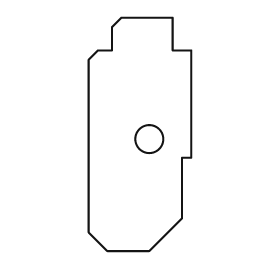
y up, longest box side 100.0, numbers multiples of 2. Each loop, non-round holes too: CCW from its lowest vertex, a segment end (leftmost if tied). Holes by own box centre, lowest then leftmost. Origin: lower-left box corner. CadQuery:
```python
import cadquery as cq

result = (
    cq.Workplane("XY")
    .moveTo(8.0, 0.0)
    .lineTo(26.0, 0.0)
    .lineTo(40.0, 14.0)
    .lineTo(40.0, 40.0)
    .lineTo(44.0, 40.0)
    .lineTo(44.0, 86.0)
    .lineTo(36.0, 86.0)
    .lineTo(36.0, 100.0)
    .lineTo(14.0, 100.0)
    .lineTo(10.0, 96.0)
    .lineTo(10.0, 86.0)
    .lineTo(4.0, 86.0)
    .lineTo(0.0, 82.0)
    .lineTo(0.0, 8.0)
    .close()
    .moveTo(26.0, 48.0)
    .circle(6.0)
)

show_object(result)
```